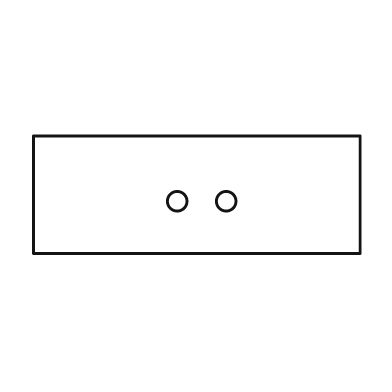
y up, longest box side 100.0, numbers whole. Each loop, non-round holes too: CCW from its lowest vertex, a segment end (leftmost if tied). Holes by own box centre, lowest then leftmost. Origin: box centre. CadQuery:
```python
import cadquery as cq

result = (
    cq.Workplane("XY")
    .moveTo(-50.0, -18.0)
    .lineTo(50.0, -18.0)
    .lineTo(50.0, 18.0)
    .lineTo(-50.0, 18.0)
    .close()
    .moveTo(-6.0, -2.0)
    .circle(3.0)
    .moveTo(9.0, -2.0)
    .circle(3.0)
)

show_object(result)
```